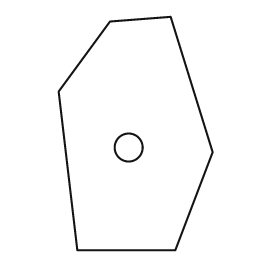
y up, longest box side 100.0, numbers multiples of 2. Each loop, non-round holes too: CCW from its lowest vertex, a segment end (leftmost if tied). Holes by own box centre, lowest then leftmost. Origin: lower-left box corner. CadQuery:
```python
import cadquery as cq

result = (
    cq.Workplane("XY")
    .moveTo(8.0, 0.0)
    .lineTo(50.0, 0.0)
    .lineTo(66.0, 42.0)
    .lineTo(48.0, 100.0)
    .lineTo(22.0, 98.0)
    .lineTo(0.0, 68.0)
    .close()
    .moveTo(30.0, 44.0)
    .circle(6.0)
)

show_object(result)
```